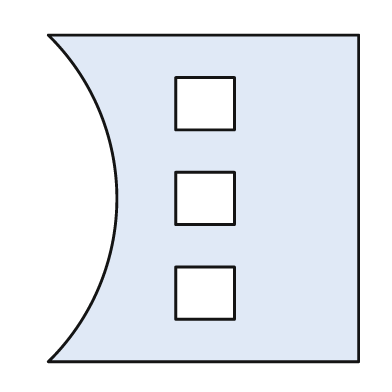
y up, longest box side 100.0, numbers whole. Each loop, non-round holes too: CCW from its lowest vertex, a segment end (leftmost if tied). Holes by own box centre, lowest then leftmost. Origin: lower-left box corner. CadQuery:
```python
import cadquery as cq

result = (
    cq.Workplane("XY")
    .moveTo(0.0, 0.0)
    .lineTo(95.0, 0.0)
    .lineTo(95.0, 100.0)
    .lineTo(0.0, 100.0)
    .threePointArc((21.0, 50.0), (0.0, 0.0))
    .close()
    .moveTo(39.0, 13.0)
    .lineTo(57.0, 13.0)
    .lineTo(57.0, 29.0)
    .lineTo(39.0, 29.0)
    .close()
    .moveTo(39.0, 42.0)
    .lineTo(57.0, 42.0)
    .lineTo(57.0, 58.0)
    .lineTo(39.0, 58.0)
    .close()
    .moveTo(39.0, 71.0)
    .lineTo(57.0, 71.0)
    .lineTo(57.0, 87.0)
    .lineTo(39.0, 87.0)
    .close()
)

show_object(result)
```